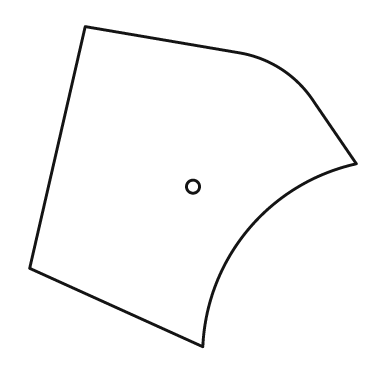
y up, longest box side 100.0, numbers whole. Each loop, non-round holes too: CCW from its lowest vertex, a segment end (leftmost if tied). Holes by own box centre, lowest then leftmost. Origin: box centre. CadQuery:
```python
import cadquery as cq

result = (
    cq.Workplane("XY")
    .moveTo(3.0, -49.0)
    .threePointArc((17.0, -13.0), (50.0, 7.0))
    .lineTo(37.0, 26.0)
    .threePointArc((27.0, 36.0), (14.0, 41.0))
    .lineTo(-33.0, 49.0)
    .lineTo(-50.0, -25.0)
    .close()
    .moveTo(0.0, 0.0)
    .circle(2.0)
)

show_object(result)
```